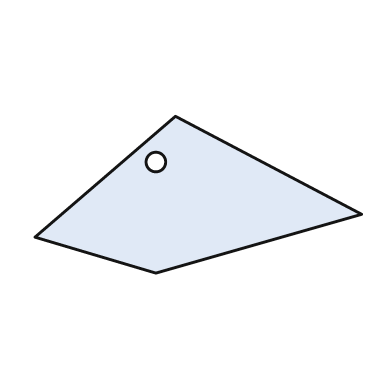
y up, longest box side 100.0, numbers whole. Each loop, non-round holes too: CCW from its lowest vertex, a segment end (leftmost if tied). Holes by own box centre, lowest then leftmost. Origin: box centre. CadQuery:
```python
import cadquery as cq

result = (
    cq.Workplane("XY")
    .moveTo(-13.0, -24.0)
    .lineTo(50.0, -6.0)
    .lineTo(-7.0, 24.0)
    .lineTo(-50.0, -13.0)
    .close()
    .moveTo(-13.0, 10.0)
    .circle(3.0)
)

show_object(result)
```